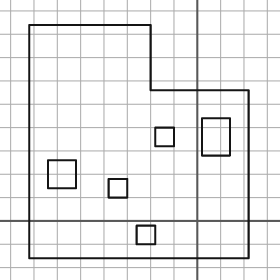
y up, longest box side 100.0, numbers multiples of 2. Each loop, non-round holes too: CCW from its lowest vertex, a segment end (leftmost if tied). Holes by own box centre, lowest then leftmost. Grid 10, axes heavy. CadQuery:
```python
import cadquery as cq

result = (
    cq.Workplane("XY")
    .moveTo(-72.0, -16.0)
    .lineTo(22.0, -16.0)
    .lineTo(22.0, 56.0)
    .lineTo(-20.0, 56.0)
    .lineTo(-20.0, 84.0)
    .lineTo(-72.0, 84.0)
    .close()
    .moveTo(-26.0, -10.0)
    .lineTo(-18.0, -10.0)
    .lineTo(-18.0, -2.0)
    .lineTo(-26.0, -2.0)
    .close()
    .moveTo(-38.0, 10.0)
    .lineTo(-30.0, 10.0)
    .lineTo(-30.0, 18.0)
    .lineTo(-38.0, 18.0)
    .close()
    .moveTo(-64.0, 14.0)
    .lineTo(-52.0, 14.0)
    .lineTo(-52.0, 26.0)
    .lineTo(-64.0, 26.0)
    .close()
    .moveTo(-18.0, 32.0)
    .lineTo(-10.0, 32.0)
    .lineTo(-10.0, 40.0)
    .lineTo(-18.0, 40.0)
    .close()
    .moveTo(2.0, 28.0)
    .lineTo(14.0, 28.0)
    .lineTo(14.0, 44.0)
    .lineTo(2.0, 44.0)
    .close()
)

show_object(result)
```